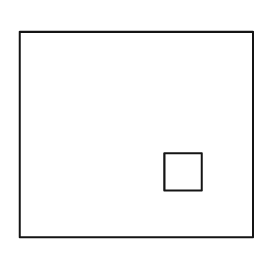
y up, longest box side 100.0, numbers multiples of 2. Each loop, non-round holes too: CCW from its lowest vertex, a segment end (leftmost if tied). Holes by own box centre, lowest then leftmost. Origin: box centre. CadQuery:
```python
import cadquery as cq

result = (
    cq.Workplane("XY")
    .moveTo(-50.0, -44.0)
    .lineTo(50.0, -44.0)
    .lineTo(50.0, 44.0)
    .lineTo(-50.0, 44.0)
    .close()
    .moveTo(12.0, -24.0)
    .lineTo(28.0, -24.0)
    .lineTo(28.0, -8.0)
    .lineTo(12.0, -8.0)
    .close()
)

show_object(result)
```